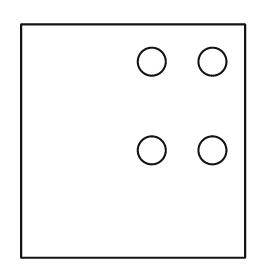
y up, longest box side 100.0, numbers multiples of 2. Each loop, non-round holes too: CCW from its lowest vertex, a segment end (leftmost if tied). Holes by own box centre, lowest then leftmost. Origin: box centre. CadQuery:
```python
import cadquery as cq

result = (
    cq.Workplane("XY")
    .moveTo(-48.0, -50.0)
    .lineTo(48.0, -50.0)
    .lineTo(48.0, 50.0)
    .lineTo(-48.0, 50.0)
    .close()
    .moveTo(8.0, -4.0)
    .circle(6.0)
    .moveTo(34.0, -4.0)
    .circle(6.0)
    .moveTo(8.0, 34.0)
    .circle(6.0)
    .moveTo(34.0, 34.0)
    .circle(6.0)
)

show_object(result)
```